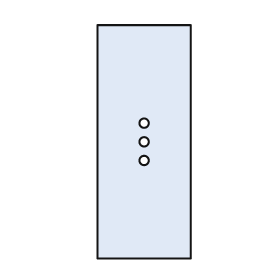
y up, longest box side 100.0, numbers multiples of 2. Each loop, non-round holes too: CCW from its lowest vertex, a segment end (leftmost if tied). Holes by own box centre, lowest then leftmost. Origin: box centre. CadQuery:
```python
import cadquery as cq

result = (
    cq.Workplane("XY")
    .moveTo(-20.0, -50.0)
    .lineTo(20.0, -50.0)
    .lineTo(20.0, 50.0)
    .lineTo(-20.0, 50.0)
    .close()
    .moveTo(0.0, -8.0)
    .circle(2.0)
    .moveTo(0.0, 0.0)
    .circle(2.0)
    .moveTo(0.0, 8.0)
    .circle(2.0)
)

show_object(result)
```